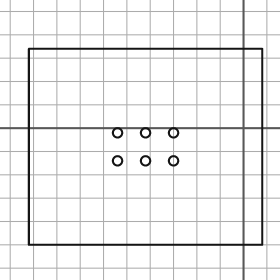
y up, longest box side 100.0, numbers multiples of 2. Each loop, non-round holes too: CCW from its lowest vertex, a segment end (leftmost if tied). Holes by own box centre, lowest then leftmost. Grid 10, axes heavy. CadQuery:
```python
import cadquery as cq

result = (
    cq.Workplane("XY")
    .moveTo(-92.0, -50.0)
    .lineTo(8.0, -50.0)
    .lineTo(8.0, 34.0)
    .lineTo(-92.0, 34.0)
    .close()
    .moveTo(-54.0, -14.0)
    .circle(2.0)
    .moveTo(-42.0, -14.0)
    .circle(2.0)
    .moveTo(-30.0, -14.0)
    .circle(2.0)
    .moveTo(-54.0, -2.0)
    .circle(2.0)
    .moveTo(-42.0, -2.0)
    .circle(2.0)
    .moveTo(-30.0, -2.0)
    .circle(2.0)
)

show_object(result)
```